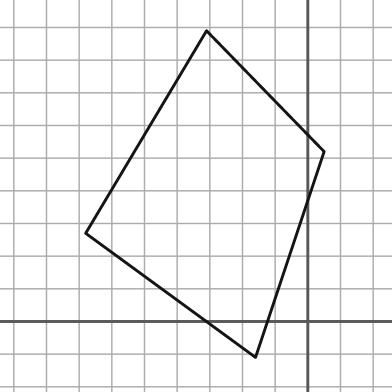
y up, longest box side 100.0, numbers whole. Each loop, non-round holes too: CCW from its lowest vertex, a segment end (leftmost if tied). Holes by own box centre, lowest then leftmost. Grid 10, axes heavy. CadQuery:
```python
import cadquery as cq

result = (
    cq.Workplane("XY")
    .moveTo(-16.0, -11.0)
    .lineTo(5.0, 52.0)
    .lineTo(-31.0, 89.0)
    .lineTo(-68.0, 27.0)
    .close()
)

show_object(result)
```